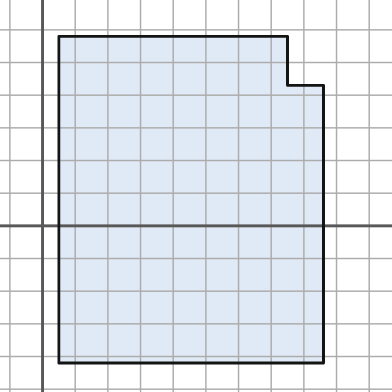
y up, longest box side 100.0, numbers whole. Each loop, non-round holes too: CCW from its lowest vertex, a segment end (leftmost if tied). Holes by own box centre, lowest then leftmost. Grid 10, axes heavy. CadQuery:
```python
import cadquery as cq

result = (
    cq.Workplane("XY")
    .moveTo(5.0, -42.0)
    .lineTo(86.0, -42.0)
    .lineTo(86.0, 43.0)
    .lineTo(75.0, 43.0)
    .lineTo(75.0, 58.0)
    .lineTo(5.0, 58.0)
    .close()
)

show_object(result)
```